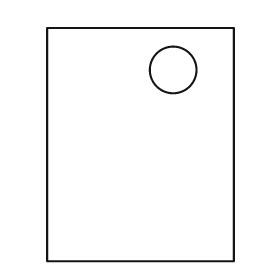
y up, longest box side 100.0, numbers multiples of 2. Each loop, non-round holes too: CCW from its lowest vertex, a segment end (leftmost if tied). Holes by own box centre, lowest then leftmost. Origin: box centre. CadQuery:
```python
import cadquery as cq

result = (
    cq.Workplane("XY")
    .moveTo(-40.0, -50.0)
    .lineTo(40.0, -50.0)
    .lineTo(40.0, 50.0)
    .lineTo(-40.0, 50.0)
    .close()
    .moveTo(14.0, 32.0)
    .circle(10.0)
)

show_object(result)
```